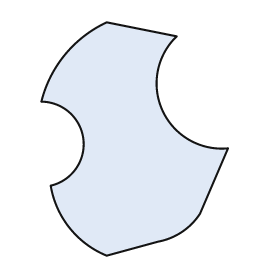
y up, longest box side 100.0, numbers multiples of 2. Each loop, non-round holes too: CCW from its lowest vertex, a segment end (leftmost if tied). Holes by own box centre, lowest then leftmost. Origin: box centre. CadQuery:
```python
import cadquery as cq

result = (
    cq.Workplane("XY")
    .moveTo(-12.0, -50.0)
    .lineTo(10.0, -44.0)
    .threePointArc((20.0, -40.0), (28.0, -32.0))
    .lineTo(40.0, -4.0)
    .threePointArc((12.0, 12.0), (18.0, 44.0))
    .lineTo(-12.0, 50.0)
    .threePointArc((-30.0, 36.0), (-40.0, 16.0))
    .threePointArc((-22.0, 0.0), (-36.0, -20.0))
    .threePointArc((-28.0, -38.0), (-12.0, -50.0))
    .close()
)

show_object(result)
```